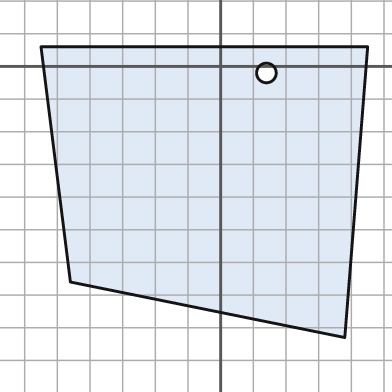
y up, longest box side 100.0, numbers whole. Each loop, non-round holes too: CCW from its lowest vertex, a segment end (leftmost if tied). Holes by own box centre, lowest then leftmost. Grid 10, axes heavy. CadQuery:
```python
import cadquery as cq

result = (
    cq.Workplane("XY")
    .moveTo(38.0, -83.0)
    .lineTo(45.0, 6.0)
    .lineTo(-55.0, 6.0)
    .lineTo(-46.0, -66.0)
    .close()
    .moveTo(14.0, -2.0)
    .circle(3.0)
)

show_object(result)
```